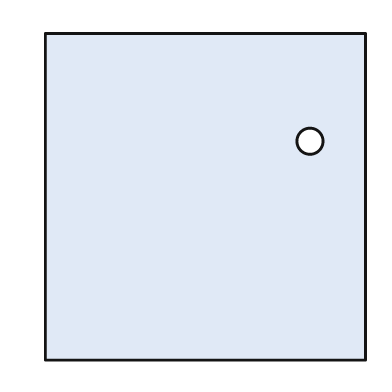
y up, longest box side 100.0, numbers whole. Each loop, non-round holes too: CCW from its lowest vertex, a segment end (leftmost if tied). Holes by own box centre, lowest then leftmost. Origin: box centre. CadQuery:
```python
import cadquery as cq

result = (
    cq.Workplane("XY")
    .moveTo(-49.0, -50.0)
    .lineTo(49.0, -50.0)
    .lineTo(49.0, 50.0)
    .lineTo(-49.0, 50.0)
    .close()
    .moveTo(32.0, 17.0)
    .circle(4.0)
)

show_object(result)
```